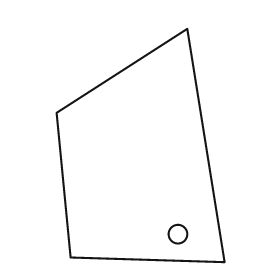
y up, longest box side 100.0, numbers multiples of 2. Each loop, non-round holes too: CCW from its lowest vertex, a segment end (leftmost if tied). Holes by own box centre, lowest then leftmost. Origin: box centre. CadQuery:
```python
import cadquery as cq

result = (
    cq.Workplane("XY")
    .moveTo(36.0, -50.0)
    .lineTo(20.0, 50.0)
    .lineTo(-36.0, 14.0)
    .lineTo(-30.0, -48.0)
    .close()
    .moveTo(16.0, -38.0)
    .circle(4.0)
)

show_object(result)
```